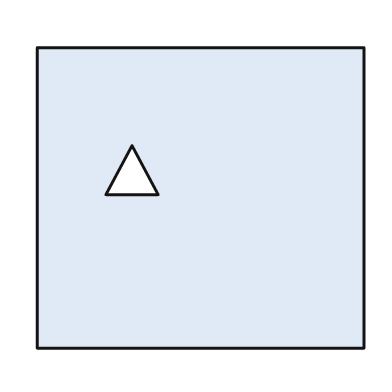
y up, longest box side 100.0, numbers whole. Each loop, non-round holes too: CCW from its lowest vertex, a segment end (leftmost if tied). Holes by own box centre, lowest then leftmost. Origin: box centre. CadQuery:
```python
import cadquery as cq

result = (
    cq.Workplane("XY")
    .moveTo(-50.0, -46.0)
    .lineTo(50.0, -46.0)
    .lineTo(50.0, 46.0)
    .lineTo(-50.0, 46.0)
    .close()
    .moveTo(-29.0, 1.0)
    .lineTo(-13.0, 1.0)
    .lineTo(-21.0, 16.0)
    .close()
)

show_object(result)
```